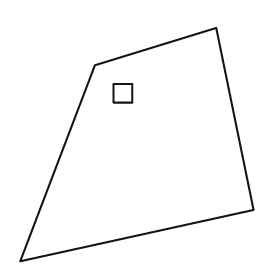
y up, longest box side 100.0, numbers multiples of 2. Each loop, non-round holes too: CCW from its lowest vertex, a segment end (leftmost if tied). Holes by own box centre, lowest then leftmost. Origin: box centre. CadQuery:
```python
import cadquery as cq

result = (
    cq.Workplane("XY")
    .moveTo(-50.0, -50.0)
    .lineTo(50.0, -28.0)
    .lineTo(34.0, 50.0)
    .lineTo(-18.0, 34.0)
    .close()
    .moveTo(-10.0, 18.0)
    .lineTo(-2.0, 18.0)
    .lineTo(-2.0, 26.0)
    .lineTo(-10.0, 26.0)
    .close()
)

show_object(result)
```